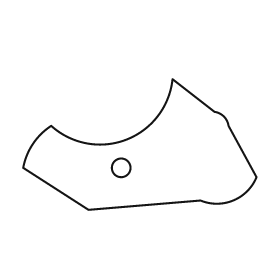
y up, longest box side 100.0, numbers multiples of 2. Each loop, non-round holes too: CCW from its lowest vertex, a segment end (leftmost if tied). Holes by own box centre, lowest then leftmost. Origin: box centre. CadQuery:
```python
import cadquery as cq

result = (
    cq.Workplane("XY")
    .moveTo(-22.0, -28.0)
    .lineTo(26.0, -24.0)
    .threePointArc((40.0, -24.0), (50.0, -14.0))
    .lineTo(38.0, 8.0)
    .threePointArc((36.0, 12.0), (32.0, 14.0))
    .lineTo(14.0, 28.0)
    .threePointArc((-6.0, 2.0), (-38.0, 8.0))
    .threePointArc((-46.0, 0.0), (-50.0, -10.0))
    .close()
    .moveTo(-8.0, -10.0)
    .circle(4.0)
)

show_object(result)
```